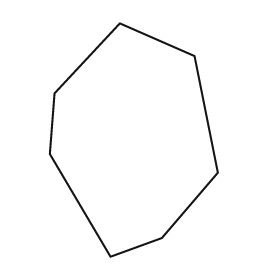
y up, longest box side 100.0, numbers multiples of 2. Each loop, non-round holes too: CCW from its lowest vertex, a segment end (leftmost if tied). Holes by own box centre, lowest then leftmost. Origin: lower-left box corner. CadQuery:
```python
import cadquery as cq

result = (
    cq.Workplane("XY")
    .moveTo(26.0, 0.0)
    .lineTo(48.0, 8.0)
    .lineTo(72.0, 36.0)
    .lineTo(62.0, 86.0)
    .lineTo(30.0, 100.0)
    .lineTo(2.0, 70.0)
    .lineTo(0.0, 44.0)
    .close()
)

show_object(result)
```